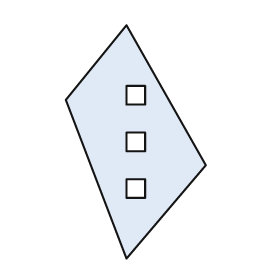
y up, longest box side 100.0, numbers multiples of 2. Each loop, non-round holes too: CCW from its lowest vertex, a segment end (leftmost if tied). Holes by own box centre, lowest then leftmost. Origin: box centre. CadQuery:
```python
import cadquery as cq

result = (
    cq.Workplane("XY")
    .moveTo(-4.0, -50.0)
    .lineTo(30.0, -10.0)
    .lineTo(-4.0, 50.0)
    .lineTo(-30.0, 18.0)
    .close()
    .moveTo(-4.0, -24.0)
    .lineTo(4.0, -24.0)
    .lineTo(4.0, -16.0)
    .lineTo(-4.0, -16.0)
    .close()
    .moveTo(-4.0, -4.0)
    .lineTo(4.0, -4.0)
    .lineTo(4.0, 4.0)
    .lineTo(-4.0, 4.0)
    .close()
    .moveTo(-4.0, 16.0)
    .lineTo(4.0, 16.0)
    .lineTo(4.0, 24.0)
    .lineTo(-4.0, 24.0)
    .close()
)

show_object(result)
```